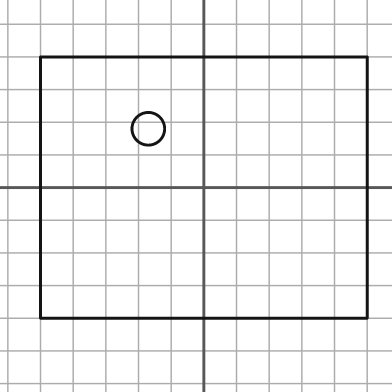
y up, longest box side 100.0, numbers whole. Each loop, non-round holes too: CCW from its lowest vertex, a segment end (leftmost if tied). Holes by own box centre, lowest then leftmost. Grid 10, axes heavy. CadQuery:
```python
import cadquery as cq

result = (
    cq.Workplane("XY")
    .moveTo(-50.0, -40.0)
    .lineTo(50.0, -40.0)
    .lineTo(50.0, 40.0)
    .lineTo(-50.0, 40.0)
    .close()
    .moveTo(-17.0, 18.0)
    .circle(5.0)
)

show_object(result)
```